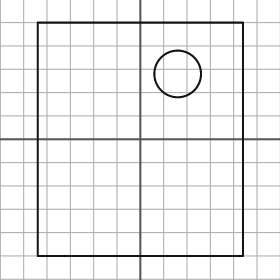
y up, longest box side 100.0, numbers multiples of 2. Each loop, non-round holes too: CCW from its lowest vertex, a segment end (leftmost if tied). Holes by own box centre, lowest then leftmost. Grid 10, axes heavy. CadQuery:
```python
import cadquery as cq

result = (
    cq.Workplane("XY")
    .moveTo(-44.0, -50.0)
    .lineTo(44.0, -50.0)
    .lineTo(44.0, 50.0)
    .lineTo(-44.0, 50.0)
    .close()
    .moveTo(16.0, 28.0)
    .circle(10.0)
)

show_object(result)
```